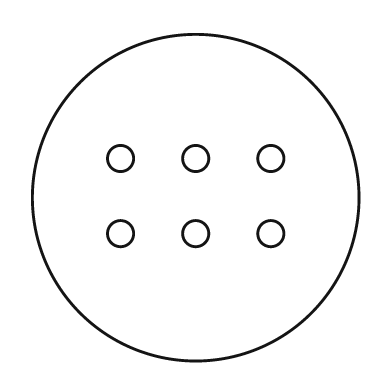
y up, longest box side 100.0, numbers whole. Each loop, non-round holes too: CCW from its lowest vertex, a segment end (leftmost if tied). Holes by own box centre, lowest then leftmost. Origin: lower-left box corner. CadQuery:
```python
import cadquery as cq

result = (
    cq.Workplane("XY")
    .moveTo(50.0, 50.0)
    .circle(50.0)
    .moveTo(27.0, 39.0)
    .circle(4.0)
    .moveTo(50.0, 39.0)
    .circle(4.0)
    .moveTo(73.0, 39.0)
    .circle(4.0)
    .moveTo(27.0, 62.0)
    .circle(4.0)
    .moveTo(50.0, 62.0)
    .circle(4.0)
    .moveTo(73.0, 62.0)
    .circle(4.0)
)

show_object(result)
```